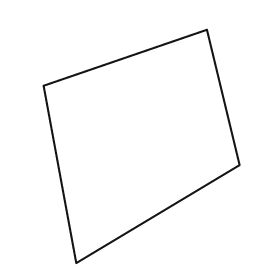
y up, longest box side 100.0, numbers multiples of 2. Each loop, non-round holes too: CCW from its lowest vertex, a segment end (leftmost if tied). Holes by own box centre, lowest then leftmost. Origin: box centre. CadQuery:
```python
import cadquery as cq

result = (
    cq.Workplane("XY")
    .moveTo(-28.0, -50.0)
    .lineTo(42.0, -8.0)
    .lineTo(28.0, 50.0)
    .lineTo(-42.0, 26.0)
    .close()
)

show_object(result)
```